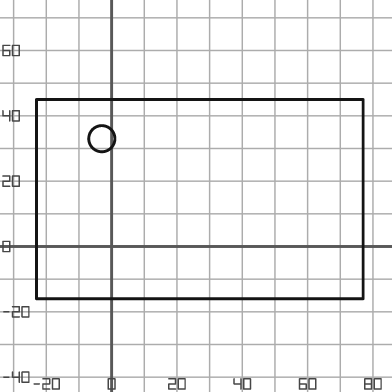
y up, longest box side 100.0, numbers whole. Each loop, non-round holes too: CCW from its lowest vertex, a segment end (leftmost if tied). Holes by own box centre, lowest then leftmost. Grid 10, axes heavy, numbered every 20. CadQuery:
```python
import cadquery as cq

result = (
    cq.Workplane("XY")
    .moveTo(-23.0, -16.0)
    .lineTo(77.0, -16.0)
    .lineTo(77.0, 45.0)
    .lineTo(-23.0, 45.0)
    .close()
    .moveTo(-3.0, 33.0)
    .circle(4.0)
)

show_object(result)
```